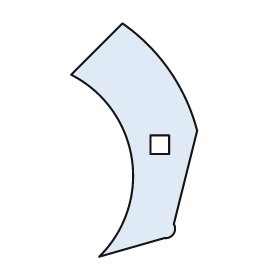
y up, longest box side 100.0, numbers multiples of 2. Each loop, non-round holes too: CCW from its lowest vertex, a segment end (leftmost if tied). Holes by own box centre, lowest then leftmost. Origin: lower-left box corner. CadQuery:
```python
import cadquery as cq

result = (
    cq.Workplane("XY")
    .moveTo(12.0, 0.0)
    .lineTo(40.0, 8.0)
    .threePointArc((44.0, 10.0), (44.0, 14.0))
    .lineTo(54.0, 54.0)
    .threePointArc((42.0, 80.0), (22.0, 100.0))
    .lineTo(0.0, 78.0)
    .threePointArc((26.0, 42.0), (12.0, 0.0))
    .close()
    .moveTo(34.0, 44.0)
    .lineTo(42.0, 44.0)
    .lineTo(42.0, 52.0)
    .lineTo(34.0, 52.0)
    .close()
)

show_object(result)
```